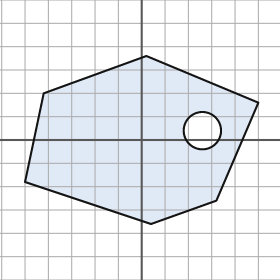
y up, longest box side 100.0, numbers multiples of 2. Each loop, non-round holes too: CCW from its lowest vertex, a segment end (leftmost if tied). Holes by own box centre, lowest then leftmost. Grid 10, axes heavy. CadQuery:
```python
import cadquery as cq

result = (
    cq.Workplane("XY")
    .moveTo(4.0, -36.0)
    .lineTo(32.0, -26.0)
    .lineTo(50.0, 16.0)
    .lineTo(2.0, 36.0)
    .lineTo(-42.0, 20.0)
    .lineTo(-50.0, -18.0)
    .close()
    .moveTo(26.0, 4.0)
    .circle(8.0)
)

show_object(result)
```